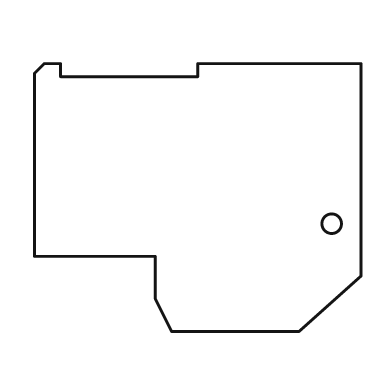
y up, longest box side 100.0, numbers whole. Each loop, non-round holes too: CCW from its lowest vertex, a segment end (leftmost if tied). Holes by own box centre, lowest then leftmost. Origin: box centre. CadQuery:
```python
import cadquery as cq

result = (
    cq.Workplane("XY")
    .moveTo(-8.0, -41.0)
    .lineTo(31.0, -41.0)
    .lineTo(50.0, -24.0)
    .lineTo(50.0, 41.0)
    .lineTo(0.0, 41.0)
    .lineTo(0.0, 37.0)
    .lineTo(-42.0, 37.0)
    .lineTo(-42.0, 41.0)
    .lineTo(-47.0, 41.0)
    .lineTo(-50.0, 38.0)
    .lineTo(-50.0, -18.0)
    .lineTo(-13.0, -18.0)
    .lineTo(-13.0, -31.0)
    .close()
    .moveTo(41.0, -8.0)
    .circle(3.0)
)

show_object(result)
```